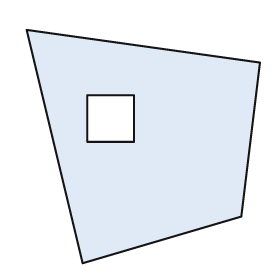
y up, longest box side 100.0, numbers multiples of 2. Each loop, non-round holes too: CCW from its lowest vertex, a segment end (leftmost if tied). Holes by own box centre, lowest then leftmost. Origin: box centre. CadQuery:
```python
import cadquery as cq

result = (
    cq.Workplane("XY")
    .moveTo(-26.0, -50.0)
    .lineTo(42.0, -30.0)
    .lineTo(50.0, 36.0)
    .lineTo(-50.0, 50.0)
    .close()
    .moveTo(-24.0, 2.0)
    .lineTo(-4.0, 2.0)
    .lineTo(-4.0, 22.0)
    .lineTo(-24.0, 22.0)
    .close()
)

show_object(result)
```